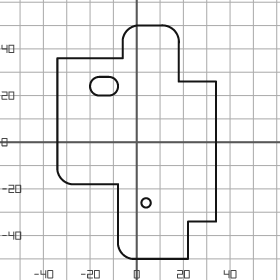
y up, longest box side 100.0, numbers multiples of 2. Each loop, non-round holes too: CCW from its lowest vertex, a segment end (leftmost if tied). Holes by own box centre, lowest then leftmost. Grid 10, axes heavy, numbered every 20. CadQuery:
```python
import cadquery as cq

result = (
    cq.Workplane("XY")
    .moveTo(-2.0, -50.0)
    .lineTo(22.0, -50.0)
    .lineTo(22.0, -34.0)
    .lineTo(34.0, -34.0)
    .lineTo(34.0, 26.0)
    .lineTo(18.0, 26.0)
    .lineTo(18.0, 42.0)
    .threePointArc((16.0, 48.0), (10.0, 50.0))
    .lineTo(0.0, 50.0)
    .threePointArc((-4.0, 48.0), (-6.0, 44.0))
    .lineTo(-6.0, 36.0)
    .lineTo(-34.0, 36.0)
    .lineTo(-34.0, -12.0)
    .threePointArc((-32.0, -16.0), (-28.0, -18.0))
    .lineTo(-8.0, -18.0)
    .lineTo(-8.0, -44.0)
    .threePointArc((-6.0, -48.0), (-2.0, -50.0))
    .close()
    .moveTo(4.0, -26.0)
    .circle(2.0)
    .moveTo(-16.0, 20.0)
    .lineTo(-12.0, 20.0)
    .threePointArc((-8.0, 24.0), (-12.0, 28.0))
    .lineTo(-16.0, 28.0)
    .threePointArc((-20.0, 24.0), (-16.0, 20.0))
    .close()
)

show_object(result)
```